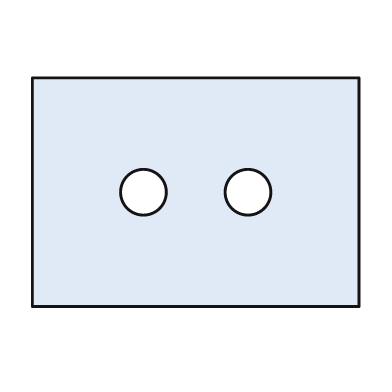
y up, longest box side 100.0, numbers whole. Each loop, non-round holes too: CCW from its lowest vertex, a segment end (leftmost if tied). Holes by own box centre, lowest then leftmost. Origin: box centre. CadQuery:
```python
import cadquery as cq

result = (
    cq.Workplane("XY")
    .moveTo(-50.0, -35.0)
    .lineTo(50.0, -35.0)
    .lineTo(50.0, 35.0)
    .lineTo(-50.0, 35.0)
    .close()
    .moveTo(-16.0, 0.0)
    .circle(7.0)
    .moveTo(16.0, 0.0)
    .circle(7.0)
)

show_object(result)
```